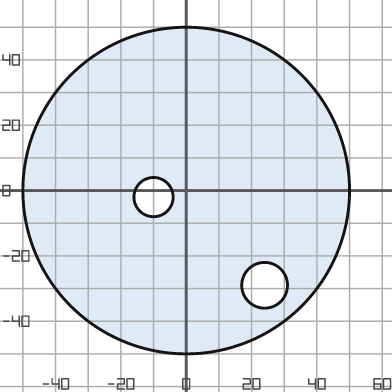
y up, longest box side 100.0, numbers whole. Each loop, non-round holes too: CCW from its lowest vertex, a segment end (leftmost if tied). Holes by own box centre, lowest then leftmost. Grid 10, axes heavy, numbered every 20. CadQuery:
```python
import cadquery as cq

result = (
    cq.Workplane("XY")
    .moveTo(0.0, 0.0)
    .circle(50.0)
    .moveTo(24.0, -29.0)
    .circle(7.0)
    .moveTo(-10.0, -2.0)
    .circle(6.0)
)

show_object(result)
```